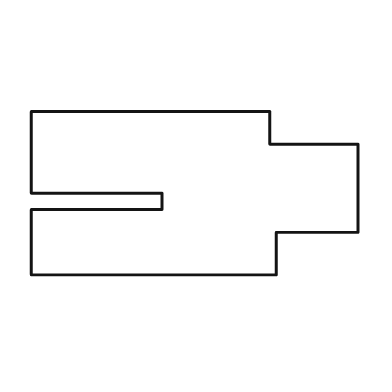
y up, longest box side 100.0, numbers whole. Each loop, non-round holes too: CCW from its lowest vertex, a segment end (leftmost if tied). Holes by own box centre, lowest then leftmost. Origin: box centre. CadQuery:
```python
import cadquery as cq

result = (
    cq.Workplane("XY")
    .moveTo(-50.0, -25.0)
    .lineTo(25.0, -25.0)
    .lineTo(25.0, -12.0)
    .lineTo(50.0, -12.0)
    .lineTo(50.0, 15.0)
    .lineTo(23.0, 15.0)
    .lineTo(23.0, 25.0)
    .lineTo(-50.0, 25.0)
    .lineTo(-50.0, 0.0)
    .lineTo(-10.0, 0.0)
    .lineTo(-10.0, -5.0)
    .lineTo(-50.0, -5.0)
    .close()
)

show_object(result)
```